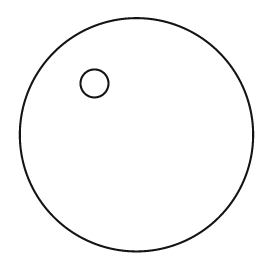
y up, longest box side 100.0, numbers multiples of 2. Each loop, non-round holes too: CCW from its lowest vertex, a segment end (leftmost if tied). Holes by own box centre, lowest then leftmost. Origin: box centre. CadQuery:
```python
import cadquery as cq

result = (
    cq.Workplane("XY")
    .moveTo(0.0, 0.0)
    .circle(50.0)
    .moveTo(-18.0, 22.0)
    .circle(6.0)
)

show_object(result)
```